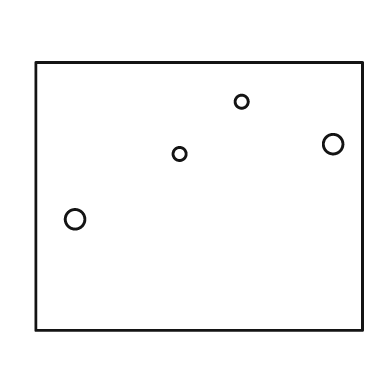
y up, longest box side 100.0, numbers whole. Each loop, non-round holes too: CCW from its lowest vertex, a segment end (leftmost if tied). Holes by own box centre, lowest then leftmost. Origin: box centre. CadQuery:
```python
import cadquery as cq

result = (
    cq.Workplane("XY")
    .moveTo(-50.0, -41.0)
    .lineTo(50.0, -41.0)
    .lineTo(50.0, 41.0)
    .lineTo(-50.0, 41.0)
    .close()
    .moveTo(-38.0, -7.0)
    .circle(3.0)
    .moveTo(-6.0, 13.0)
    .circle(2.0)
    .moveTo(41.0, 16.0)
    .circle(3.0)
    .moveTo(13.0, 29.0)
    .circle(2.0)
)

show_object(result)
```